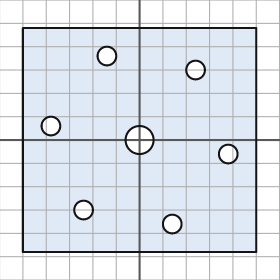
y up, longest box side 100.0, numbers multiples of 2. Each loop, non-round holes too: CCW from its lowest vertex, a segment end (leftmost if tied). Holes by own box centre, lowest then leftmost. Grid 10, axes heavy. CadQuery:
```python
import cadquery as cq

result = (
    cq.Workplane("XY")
    .moveTo(-50.0, -48.0)
    .lineTo(50.0, -48.0)
    .lineTo(50.0, 48.0)
    .lineTo(-50.0, 48.0)
    .close()
    .moveTo(14.0, -36.0)
    .circle(4.0)
    .moveTo(-24.0, -30.0)
    .circle(4.0)
    .moveTo(38.0, -6.0)
    .circle(4.0)
    .moveTo(0.0, 0.0)
    .circle(6.0)
    .moveTo(-38.0, 6.0)
    .circle(4.0)
    .moveTo(24.0, 30.0)
    .circle(4.0)
    .moveTo(-14.0, 36.0)
    .circle(4.0)
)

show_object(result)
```